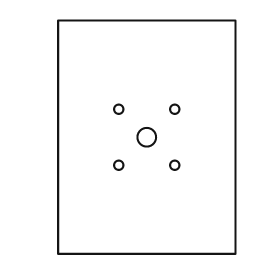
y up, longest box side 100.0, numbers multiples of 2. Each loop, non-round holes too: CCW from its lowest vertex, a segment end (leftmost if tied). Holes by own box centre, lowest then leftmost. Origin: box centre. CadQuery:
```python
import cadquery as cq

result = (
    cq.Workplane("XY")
    .moveTo(-38.0, -50.0)
    .lineTo(38.0, -50.0)
    .lineTo(38.0, 50.0)
    .lineTo(-38.0, 50.0)
    .close()
    .moveTo(-12.0, -12.0)
    .circle(2.0)
    .moveTo(12.0, -12.0)
    .circle(2.0)
    .moveTo(0.0, 0.0)
    .circle(4.0)
    .moveTo(-12.0, 12.0)
    .circle(2.0)
    .moveTo(12.0, 12.0)
    .circle(2.0)
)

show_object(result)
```